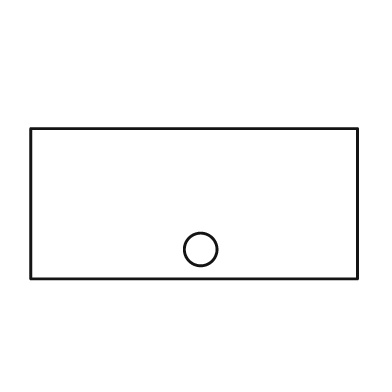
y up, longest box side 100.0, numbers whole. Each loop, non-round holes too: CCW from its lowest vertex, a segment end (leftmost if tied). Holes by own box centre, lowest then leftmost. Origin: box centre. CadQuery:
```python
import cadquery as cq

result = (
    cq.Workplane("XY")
    .moveTo(-50.0, -23.0)
    .lineTo(50.0, -23.0)
    .lineTo(50.0, 23.0)
    .lineTo(-50.0, 23.0)
    .close()
    .moveTo(2.0, -14.0)
    .circle(5.0)
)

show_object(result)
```